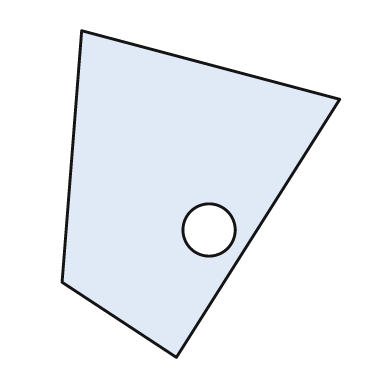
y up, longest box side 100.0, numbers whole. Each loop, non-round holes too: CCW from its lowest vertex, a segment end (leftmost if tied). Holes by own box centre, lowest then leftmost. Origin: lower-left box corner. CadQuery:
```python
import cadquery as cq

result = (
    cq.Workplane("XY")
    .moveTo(35.0, 0.0)
    .lineTo(85.0, 79.0)
    .lineTo(6.0, 100.0)
    .lineTo(0.0, 23.0)
    .close()
    .moveTo(45.0, 39.0)
    .circle(8.0)
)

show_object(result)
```